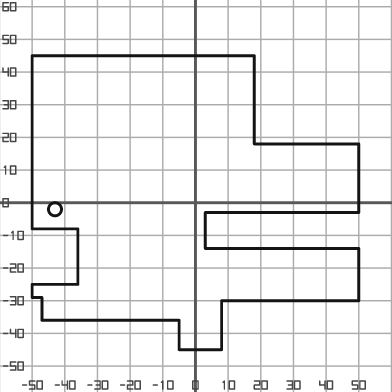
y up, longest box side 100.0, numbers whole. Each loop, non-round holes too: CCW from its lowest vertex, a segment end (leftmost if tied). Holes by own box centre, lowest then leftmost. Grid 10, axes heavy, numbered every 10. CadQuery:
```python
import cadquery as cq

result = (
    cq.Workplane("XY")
    .moveTo(-5.0, -45.0)
    .lineTo(8.0, -45.0)
    .lineTo(8.0, -30.0)
    .lineTo(50.0, -30.0)
    .lineTo(50.0, -14.0)
    .lineTo(3.0, -14.0)
    .lineTo(3.0, -3.0)
    .lineTo(50.0, -3.0)
    .lineTo(50.0, 18.0)
    .lineTo(18.0, 18.0)
    .lineTo(18.0, 45.0)
    .lineTo(-50.0, 45.0)
    .lineTo(-50.0, -8.0)
    .lineTo(-36.0, -8.0)
    .lineTo(-36.0, -25.0)
    .lineTo(-50.0, -25.0)
    .lineTo(-50.0, -29.0)
    .lineTo(-47.0, -29.0)
    .lineTo(-47.0, -36.0)
    .lineTo(-5.0, -36.0)
    .close()
    .moveTo(-43.0, -2.0)
    .circle(2.0)
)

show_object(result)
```